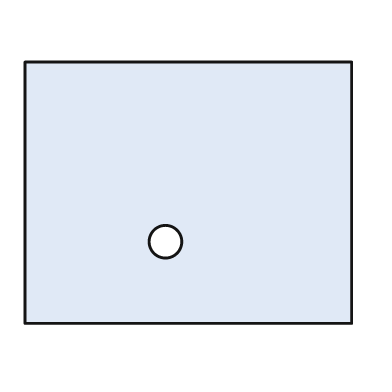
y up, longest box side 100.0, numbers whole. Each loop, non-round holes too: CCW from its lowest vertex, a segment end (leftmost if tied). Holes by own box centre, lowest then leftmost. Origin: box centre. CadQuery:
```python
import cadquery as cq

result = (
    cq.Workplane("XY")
    .moveTo(-50.0, -40.0)
    .lineTo(50.0, -40.0)
    .lineTo(50.0, 40.0)
    .lineTo(-50.0, 40.0)
    .close()
    .moveTo(-7.0, -15.0)
    .circle(5.0)
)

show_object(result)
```